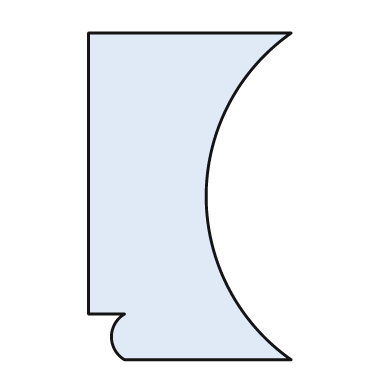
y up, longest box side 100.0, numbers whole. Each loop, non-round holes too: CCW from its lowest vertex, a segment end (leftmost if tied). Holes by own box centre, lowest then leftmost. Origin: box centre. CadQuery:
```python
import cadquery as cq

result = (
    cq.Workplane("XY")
    .moveTo(-20.0, -50.0)
    .lineTo(31.0, -50.0)
    .threePointArc((5.0, 0.0), (31.0, 50.0))
    .lineTo(-31.0, 50.0)
    .lineTo(-31.0, -36.0)
    .lineTo(-20.0, -36.0)
    .threePointArc((-24.0, -43.0), (-20.0, -50.0))
    .close()
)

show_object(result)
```